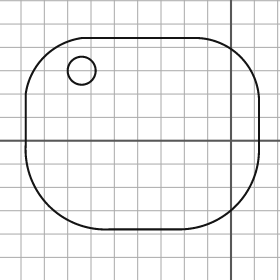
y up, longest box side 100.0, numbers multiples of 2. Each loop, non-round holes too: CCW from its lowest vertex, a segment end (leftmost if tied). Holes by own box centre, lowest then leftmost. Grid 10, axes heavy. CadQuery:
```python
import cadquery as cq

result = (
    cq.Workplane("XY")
    .moveTo(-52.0, -38.0)
    .lineTo(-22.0, -38.0)
    .threePointArc((2.0, -28.0), (12.0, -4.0))
    .lineTo(12.0, 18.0)
    .threePointArc((4.0, 36.0), (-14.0, 44.0))
    .lineTo(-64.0, 44.0)
    .threePointArc((-80.0, 36.0), (-88.0, 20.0))
    .lineTo(-88.0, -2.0)
    .threePointArc((-78.0, -28.0), (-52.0, -38.0))
    .close()
    .moveTo(-64.0, 30.0)
    .circle(6.0)
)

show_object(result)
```